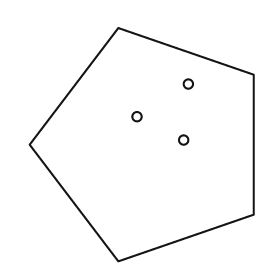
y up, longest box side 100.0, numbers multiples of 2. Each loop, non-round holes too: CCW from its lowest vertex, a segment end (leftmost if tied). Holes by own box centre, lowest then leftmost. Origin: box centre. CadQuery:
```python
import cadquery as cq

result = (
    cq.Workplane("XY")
    .moveTo(-10.0, -50.0)
    .lineTo(48.0, -30.0)
    .lineTo(48.0, 30.0)
    .lineTo(-10.0, 50.0)
    .lineTo(-48.0, 0.0)
    .close()
    .moveTo(18.0, 2.0)
    .circle(2.0)
    .moveTo(-2.0, 12.0)
    .circle(2.0)
    .moveTo(20.0, 26.0)
    .circle(2.0)
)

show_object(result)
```